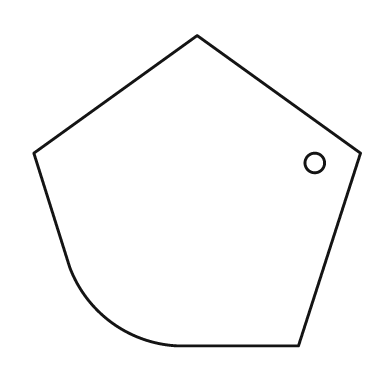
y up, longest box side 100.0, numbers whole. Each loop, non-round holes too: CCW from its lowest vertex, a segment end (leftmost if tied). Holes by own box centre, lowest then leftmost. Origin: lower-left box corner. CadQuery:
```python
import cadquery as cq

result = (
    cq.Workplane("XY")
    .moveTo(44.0, 0.0)
    .lineTo(81.0, 0.0)
    .lineTo(100.0, 59.0)
    .lineTo(50.0, 95.0)
    .lineTo(0.0, 59.0)
    .lineTo(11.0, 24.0)
    .threePointArc((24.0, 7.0), (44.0, 0.0))
    .close()
    .moveTo(86.0, 56.0)
    .circle(3.0)
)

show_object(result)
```